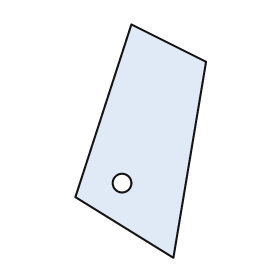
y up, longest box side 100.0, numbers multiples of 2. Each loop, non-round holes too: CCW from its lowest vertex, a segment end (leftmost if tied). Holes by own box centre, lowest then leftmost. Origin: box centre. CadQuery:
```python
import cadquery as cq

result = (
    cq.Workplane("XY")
    .moveTo(14.0, -50.0)
    .lineTo(28.0, 34.0)
    .lineTo(-4.0, 50.0)
    .lineTo(-28.0, -24.0)
    .close()
    .moveTo(-8.0, -18.0)
    .circle(4.0)
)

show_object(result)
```